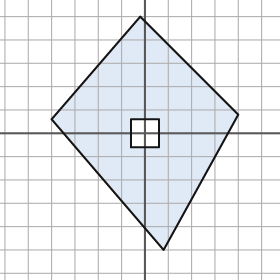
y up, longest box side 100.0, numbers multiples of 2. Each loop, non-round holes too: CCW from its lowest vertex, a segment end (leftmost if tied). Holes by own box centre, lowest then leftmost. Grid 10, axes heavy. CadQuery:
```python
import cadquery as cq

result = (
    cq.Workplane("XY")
    .moveTo(8.0, -50.0)
    .lineTo(40.0, 8.0)
    .lineTo(-2.0, 50.0)
    .lineTo(-40.0, 6.0)
    .close()
    .moveTo(-6.0, -6.0)
    .lineTo(6.0, -6.0)
    .lineTo(6.0, 6.0)
    .lineTo(-6.0, 6.0)
    .close()
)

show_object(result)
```